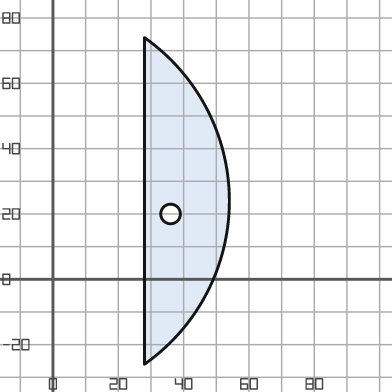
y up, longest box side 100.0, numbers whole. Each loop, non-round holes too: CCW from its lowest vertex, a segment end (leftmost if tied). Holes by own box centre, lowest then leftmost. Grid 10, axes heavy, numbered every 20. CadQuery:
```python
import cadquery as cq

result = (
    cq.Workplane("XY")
    .moveTo(28.0, -26.0)
    .threePointArc((54.0, 24.0), (28.0, 74.0))
    .close()
    .moveTo(36.0, 20.0)
    .circle(3.0)
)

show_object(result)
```